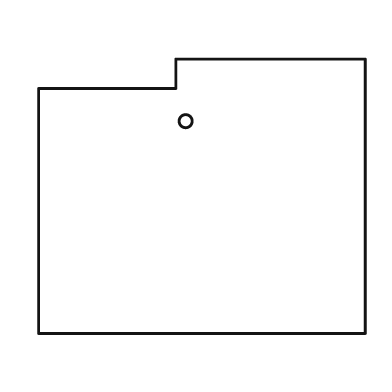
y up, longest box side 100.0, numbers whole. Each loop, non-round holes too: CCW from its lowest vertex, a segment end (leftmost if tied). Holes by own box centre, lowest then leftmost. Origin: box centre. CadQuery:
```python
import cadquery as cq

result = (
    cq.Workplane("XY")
    .moveTo(-50.0, -42.0)
    .lineTo(50.0, -42.0)
    .lineTo(50.0, 42.0)
    .lineTo(-8.0, 42.0)
    .lineTo(-8.0, 33.0)
    .lineTo(-50.0, 33.0)
    .close()
    .moveTo(-5.0, 23.0)
    .circle(2.0)
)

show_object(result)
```